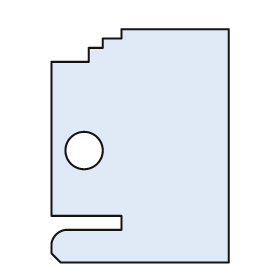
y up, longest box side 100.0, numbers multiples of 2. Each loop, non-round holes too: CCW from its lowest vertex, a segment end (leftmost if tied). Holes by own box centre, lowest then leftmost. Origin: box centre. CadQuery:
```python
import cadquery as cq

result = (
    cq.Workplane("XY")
    .moveTo(-34.0, -50.0)
    .lineTo(38.0, -50.0)
    .lineTo(38.0, 50.0)
    .lineTo(-8.0, 50.0)
    .lineTo(-8.0, 46.0)
    .lineTo(-16.0, 46.0)
    .lineTo(-16.0, 42.0)
    .lineTo(-22.0, 42.0)
    .lineTo(-22.0, 36.0)
    .lineTo(-38.0, 36.0)
    .lineTo(-38.0, -30.0)
    .lineTo(-8.0, -30.0)
    .lineTo(-8.0, -36.0)
    .lineTo(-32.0, -36.0)
    .threePointArc((-36.0, -38.0), (-38.0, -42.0))
    .lineTo(-38.0, -46.0)
    .close()
    .moveTo(-24.0, -2.0)
    .circle(8.0)
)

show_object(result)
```